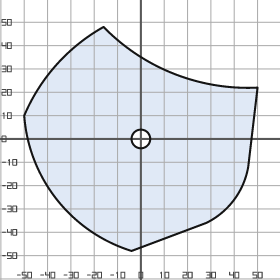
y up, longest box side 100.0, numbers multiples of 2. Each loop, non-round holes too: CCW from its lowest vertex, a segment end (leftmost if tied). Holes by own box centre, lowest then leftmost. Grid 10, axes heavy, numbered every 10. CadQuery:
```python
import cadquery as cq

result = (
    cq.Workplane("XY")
    .moveTo(-4.0, -48.0)
    .lineTo(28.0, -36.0)
    .threePointArc((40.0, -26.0), (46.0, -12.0))
    .lineTo(50.0, 22.0)
    .threePointArc((14.0, 28.0), (-16.0, 48.0))
    .threePointArc((-36.0, 32.0), (-50.0, 10.0))
    .threePointArc((-36.0, -26.0), (-4.0, -48.0))
    .close()
    .moveTo(0.0, 0.0)
    .circle(4.0)
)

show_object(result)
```